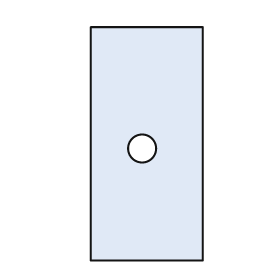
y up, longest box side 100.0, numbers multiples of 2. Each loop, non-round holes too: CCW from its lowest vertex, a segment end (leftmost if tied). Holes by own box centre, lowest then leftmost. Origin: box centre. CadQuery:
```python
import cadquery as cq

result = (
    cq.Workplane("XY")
    .moveTo(-24.0, -50.0)
    .lineTo(24.0, -50.0)
    .lineTo(24.0, 50.0)
    .lineTo(-24.0, 50.0)
    .close()
    .moveTo(-2.0, -2.0)
    .circle(6.0)
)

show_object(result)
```